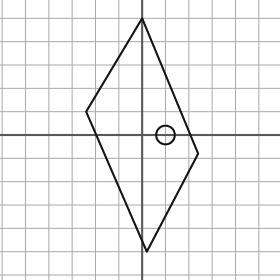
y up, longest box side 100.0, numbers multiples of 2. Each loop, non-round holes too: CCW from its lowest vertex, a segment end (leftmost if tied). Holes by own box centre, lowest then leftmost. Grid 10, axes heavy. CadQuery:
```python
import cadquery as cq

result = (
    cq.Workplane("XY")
    .moveTo(2.0, -50.0)
    .lineTo(24.0, -8.0)
    .lineTo(0.0, 50.0)
    .lineTo(-24.0, 10.0)
    .close()
    .moveTo(10.0, 0.0)
    .circle(4.0)
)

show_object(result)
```